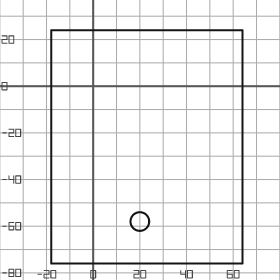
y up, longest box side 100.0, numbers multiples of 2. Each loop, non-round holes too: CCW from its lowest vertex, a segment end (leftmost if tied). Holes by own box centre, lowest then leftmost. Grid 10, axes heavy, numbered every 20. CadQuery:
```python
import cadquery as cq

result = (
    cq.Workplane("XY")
    .moveTo(-18.0, -76.0)
    .lineTo(64.0, -76.0)
    .lineTo(64.0, 24.0)
    .lineTo(-18.0, 24.0)
    .close()
    .moveTo(20.0, -58.0)
    .circle(4.0)
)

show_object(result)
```